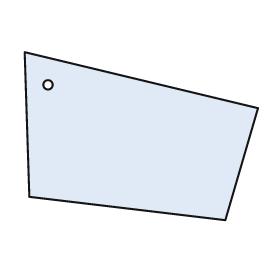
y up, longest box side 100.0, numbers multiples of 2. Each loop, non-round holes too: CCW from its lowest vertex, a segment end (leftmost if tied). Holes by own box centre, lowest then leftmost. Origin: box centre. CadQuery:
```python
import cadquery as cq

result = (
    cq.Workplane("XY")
    .moveTo(36.0, -36.0)
    .lineTo(50.0, 12.0)
    .lineTo(-50.0, 36.0)
    .lineTo(-48.0, -26.0)
    .close()
    .moveTo(-40.0, 22.0)
    .circle(2.0)
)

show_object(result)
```